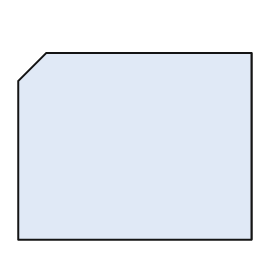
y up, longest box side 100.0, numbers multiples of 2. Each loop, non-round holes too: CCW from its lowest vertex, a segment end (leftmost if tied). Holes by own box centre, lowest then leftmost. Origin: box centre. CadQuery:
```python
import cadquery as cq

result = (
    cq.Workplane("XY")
    .moveTo(-50.0, -40.0)
    .lineTo(50.0, -40.0)
    .lineTo(50.0, 40.0)
    .lineTo(-38.0, 40.0)
    .lineTo(-50.0, 28.0)
    .close()
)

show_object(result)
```